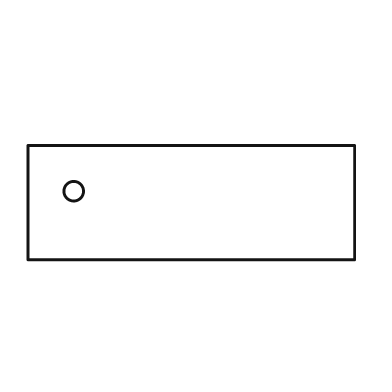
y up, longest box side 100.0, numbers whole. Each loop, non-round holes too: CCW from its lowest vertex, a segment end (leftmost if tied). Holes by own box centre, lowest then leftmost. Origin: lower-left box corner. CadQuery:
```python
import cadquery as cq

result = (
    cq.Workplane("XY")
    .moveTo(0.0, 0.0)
    .lineTo(100.0, 0.0)
    .lineTo(100.0, 35.0)
    .lineTo(0.0, 35.0)
    .close()
    .moveTo(14.0, 21.0)
    .circle(3.0)
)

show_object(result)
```